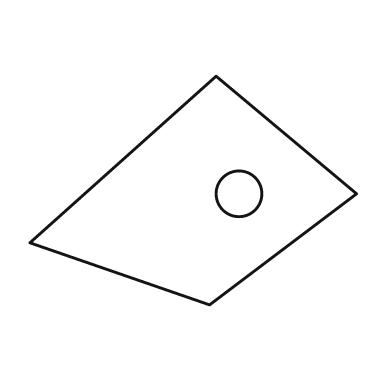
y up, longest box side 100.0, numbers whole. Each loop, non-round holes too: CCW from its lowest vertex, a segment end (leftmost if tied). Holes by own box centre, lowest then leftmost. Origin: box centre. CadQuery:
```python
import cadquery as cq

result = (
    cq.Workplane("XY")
    .moveTo(5.0, -35.0)
    .lineTo(50.0, -1.0)
    .lineTo(7.0, 35.0)
    .lineTo(-50.0, -16.0)
    .close()
    .moveTo(14.0, -1.0)
    .circle(7.0)
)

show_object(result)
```